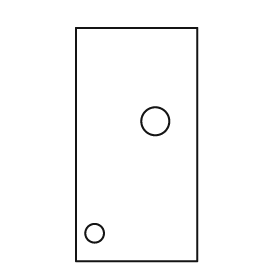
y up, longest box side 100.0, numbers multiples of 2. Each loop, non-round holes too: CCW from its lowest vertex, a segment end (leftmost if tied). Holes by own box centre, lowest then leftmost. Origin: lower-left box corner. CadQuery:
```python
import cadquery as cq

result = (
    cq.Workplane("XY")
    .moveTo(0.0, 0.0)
    .lineTo(52.0, 0.0)
    .lineTo(52.0, 100.0)
    .lineTo(0.0, 100.0)
    .close()
    .moveTo(8.0, 12.0)
    .circle(4.0)
    .moveTo(34.0, 60.0)
    .circle(6.0)
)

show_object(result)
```